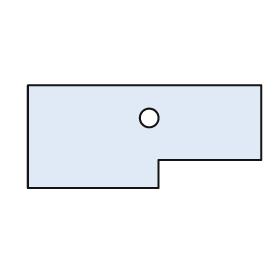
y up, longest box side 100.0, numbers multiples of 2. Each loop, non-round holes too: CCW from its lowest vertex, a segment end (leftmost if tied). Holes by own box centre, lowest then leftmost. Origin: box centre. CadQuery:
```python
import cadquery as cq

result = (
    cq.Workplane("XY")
    .moveTo(-50.0, -22.0)
    .lineTo(6.0, -22.0)
    .lineTo(6.0, -10.0)
    .lineTo(50.0, -10.0)
    .lineTo(50.0, 22.0)
    .lineTo(-50.0, 22.0)
    .close()
    .moveTo(2.0, 8.0)
    .circle(4.0)
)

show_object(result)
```